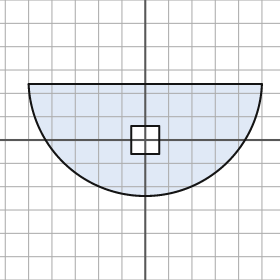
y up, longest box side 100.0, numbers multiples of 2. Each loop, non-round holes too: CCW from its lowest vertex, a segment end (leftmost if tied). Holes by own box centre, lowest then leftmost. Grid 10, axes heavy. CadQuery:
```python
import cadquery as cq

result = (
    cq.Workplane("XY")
    .moveTo(-50.0, 24.0)
    .threePointArc((0.0, -24.0), (50.0, 24.0))
    .close()
    .moveTo(-6.0, -6.0)
    .lineTo(6.0, -6.0)
    .lineTo(6.0, 6.0)
    .lineTo(-6.0, 6.0)
    .close()
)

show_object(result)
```